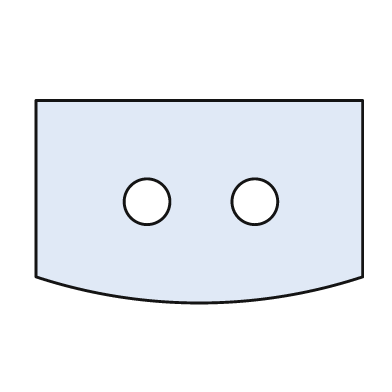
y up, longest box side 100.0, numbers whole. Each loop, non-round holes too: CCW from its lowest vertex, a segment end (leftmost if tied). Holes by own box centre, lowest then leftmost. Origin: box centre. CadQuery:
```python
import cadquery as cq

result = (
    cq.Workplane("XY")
    .moveTo(-50.0, -23.0)
    .threePointArc((0.0, -31.0), (50.0, -23.0))
    .lineTo(50.0, 31.0)
    .lineTo(-50.0, 31.0)
    .close()
    .moveTo(-16.0, 0.0)
    .circle(7.0)
    .moveTo(17.0, 0.0)
    .circle(7.0)
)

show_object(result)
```